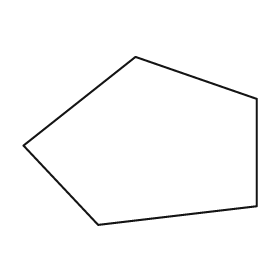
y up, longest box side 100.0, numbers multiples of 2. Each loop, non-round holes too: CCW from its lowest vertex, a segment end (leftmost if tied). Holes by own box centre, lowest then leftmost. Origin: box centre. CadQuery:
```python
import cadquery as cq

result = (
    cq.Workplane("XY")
    .moveTo(-18.0, -36.0)
    .lineTo(50.0, -28.0)
    .lineTo(50.0, 18.0)
    .lineTo(-2.0, 36.0)
    .lineTo(-50.0, -2.0)
    .close()
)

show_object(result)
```